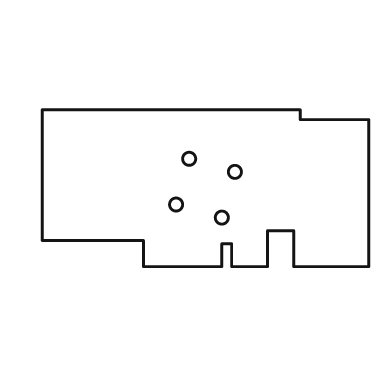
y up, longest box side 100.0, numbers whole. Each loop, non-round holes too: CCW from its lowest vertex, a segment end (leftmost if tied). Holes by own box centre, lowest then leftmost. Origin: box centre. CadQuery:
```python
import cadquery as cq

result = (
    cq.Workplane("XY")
    .moveTo(-19.0, -24.0)
    .lineTo(5.0, -24.0)
    .lineTo(5.0, -17.0)
    .lineTo(8.0, -17.0)
    .lineTo(8.0, -24.0)
    .lineTo(19.0, -24.0)
    .lineTo(19.0, -13.0)
    .lineTo(27.0, -13.0)
    .lineTo(27.0, -24.0)
    .lineTo(50.0, -24.0)
    .lineTo(50.0, 21.0)
    .lineTo(29.0, 21.0)
    .lineTo(29.0, 24.0)
    .lineTo(-50.0, 24.0)
    .lineTo(-50.0, -16.0)
    .lineTo(-19.0, -16.0)
    .close()
    .moveTo(5.0, -9.0)
    .circle(2.0)
    .moveTo(-9.0, -5.0)
    .circle(2.0)
    .moveTo(9.0, 5.0)
    .circle(2.0)
    .moveTo(-5.0, 9.0)
    .circle(2.0)
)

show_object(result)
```